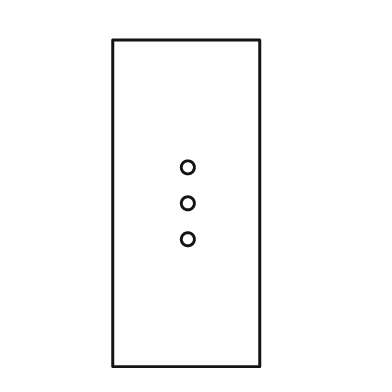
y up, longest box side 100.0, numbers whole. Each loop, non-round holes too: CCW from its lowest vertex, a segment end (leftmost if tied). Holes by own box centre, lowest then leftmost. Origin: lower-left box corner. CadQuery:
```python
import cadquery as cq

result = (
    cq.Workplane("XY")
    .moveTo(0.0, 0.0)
    .lineTo(45.0, 0.0)
    .lineTo(45.0, 100.0)
    .lineTo(0.0, 100.0)
    .close()
    .moveTo(23.0, 39.0)
    .circle(2.0)
    .moveTo(23.0, 50.0)
    .circle(2.0)
    .moveTo(23.0, 61.0)
    .circle(2.0)
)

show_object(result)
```